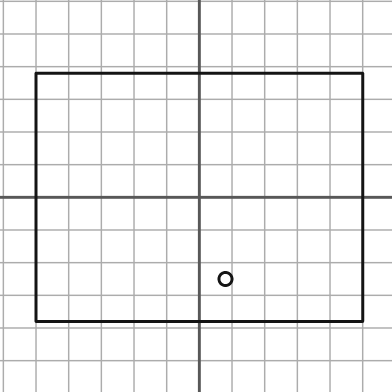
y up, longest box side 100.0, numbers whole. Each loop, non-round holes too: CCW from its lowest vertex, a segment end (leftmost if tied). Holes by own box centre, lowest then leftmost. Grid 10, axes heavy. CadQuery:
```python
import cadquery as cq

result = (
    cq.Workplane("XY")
    .moveTo(-50.0, -38.0)
    .lineTo(50.0, -38.0)
    .lineTo(50.0, 38.0)
    .lineTo(-50.0, 38.0)
    .close()
    .moveTo(8.0, -25.0)
    .circle(2.0)
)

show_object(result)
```